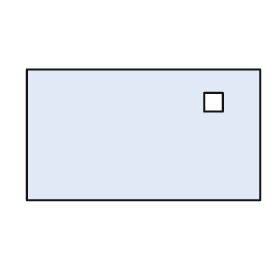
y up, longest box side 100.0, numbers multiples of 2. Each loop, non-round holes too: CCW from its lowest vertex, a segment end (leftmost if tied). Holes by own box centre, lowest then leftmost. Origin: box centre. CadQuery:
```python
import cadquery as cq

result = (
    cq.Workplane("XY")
    .moveTo(-50.0, -28.0)
    .lineTo(50.0, -28.0)
    .lineTo(50.0, 28.0)
    .lineTo(-50.0, 28.0)
    .close()
    .moveTo(26.0, 10.0)
    .lineTo(34.0, 10.0)
    .lineTo(34.0, 18.0)
    .lineTo(26.0, 18.0)
    .close()
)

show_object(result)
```